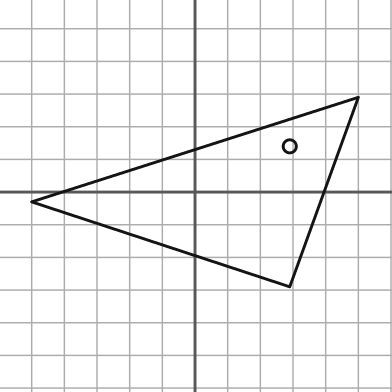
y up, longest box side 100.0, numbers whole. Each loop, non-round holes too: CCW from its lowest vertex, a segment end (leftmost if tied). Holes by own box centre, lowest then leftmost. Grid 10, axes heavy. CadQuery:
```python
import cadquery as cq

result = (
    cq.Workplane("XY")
    .moveTo(29.0, -29.0)
    .lineTo(50.0, 29.0)
    .lineTo(-50.0, -3.0)
    .close()
    .moveTo(29.0, 14.0)
    .circle(2.0)
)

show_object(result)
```